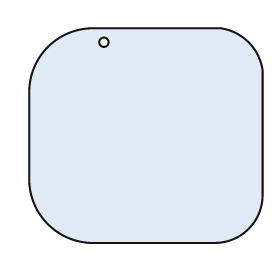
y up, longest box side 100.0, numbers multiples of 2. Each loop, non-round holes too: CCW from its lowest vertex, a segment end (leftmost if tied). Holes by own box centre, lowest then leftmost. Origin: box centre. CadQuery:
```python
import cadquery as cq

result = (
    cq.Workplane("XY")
    .moveTo(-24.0, -46.0)
    .lineTo(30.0, -46.0)
    .threePointArc((44.0, -40.0), (50.0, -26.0))
    .lineTo(50.0, 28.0)
    .threePointArc((44.0, 40.0), (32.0, 46.0))
    .lineTo(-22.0, 46.0)
    .threePointArc((-42.0, 38.0), (-50.0, 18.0))
    .lineTo(-50.0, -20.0)
    .threePointArc((-42.0, -38.0), (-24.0, -46.0))
    .close()
    .moveTo(-18.0, 40.0)
    .circle(2.0)
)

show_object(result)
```